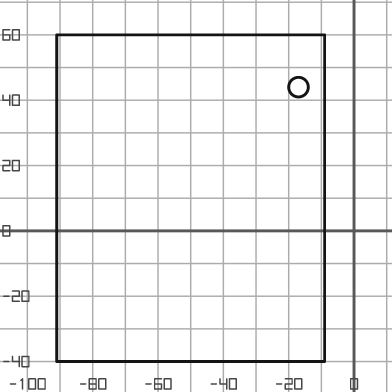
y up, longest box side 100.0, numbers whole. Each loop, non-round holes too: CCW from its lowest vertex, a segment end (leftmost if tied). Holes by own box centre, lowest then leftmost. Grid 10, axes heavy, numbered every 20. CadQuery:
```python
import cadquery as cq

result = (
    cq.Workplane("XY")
    .moveTo(-91.0, -40.0)
    .lineTo(-9.0, -40.0)
    .lineTo(-9.0, 60.0)
    .lineTo(-91.0, 60.0)
    .close()
    .moveTo(-17.0, 44.0)
    .circle(3.0)
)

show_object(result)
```